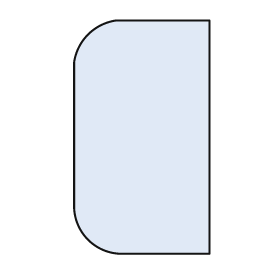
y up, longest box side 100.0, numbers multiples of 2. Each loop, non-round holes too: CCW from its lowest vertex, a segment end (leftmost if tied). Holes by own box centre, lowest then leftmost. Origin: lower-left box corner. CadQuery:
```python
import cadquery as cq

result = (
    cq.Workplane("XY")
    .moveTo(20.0, 0.0)
    .lineTo(58.0, 0.0)
    .lineTo(58.0, 100.0)
    .lineTo(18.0, 100.0)
    .threePointArc((6.0, 94.0), (0.0, 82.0))
    .lineTo(0.0, 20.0)
    .threePointArc((6.0, 6.0), (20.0, 0.0))
    .close()
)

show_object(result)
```